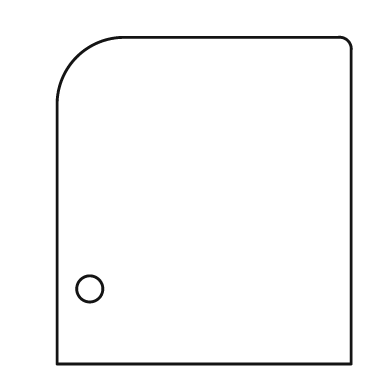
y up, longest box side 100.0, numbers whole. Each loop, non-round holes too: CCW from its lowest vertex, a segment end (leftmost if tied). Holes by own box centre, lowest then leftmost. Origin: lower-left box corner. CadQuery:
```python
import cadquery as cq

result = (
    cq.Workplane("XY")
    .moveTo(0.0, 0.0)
    .lineTo(90.0, 0.0)
    .lineTo(90.0, 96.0)
    .threePointArc((89.0, 99.0), (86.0, 100.0))
    .lineTo(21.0, 100.0)
    .threePointArc((6.0, 94.0), (0.0, 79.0))
    .close()
    .moveTo(10.0, 23.0)
    .circle(4.0)
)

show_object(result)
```